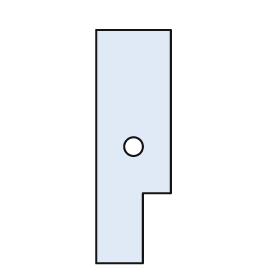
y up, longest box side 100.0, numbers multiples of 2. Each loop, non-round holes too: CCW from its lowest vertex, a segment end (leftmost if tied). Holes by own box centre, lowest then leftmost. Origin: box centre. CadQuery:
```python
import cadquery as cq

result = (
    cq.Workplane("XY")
    .moveTo(-16.0, -50.0)
    .lineTo(4.0, -50.0)
    .lineTo(4.0, -20.0)
    .lineTo(16.0, -20.0)
    .lineTo(16.0, 50.0)
    .lineTo(-16.0, 50.0)
    .close()
    .moveTo(0.0, 0.0)
    .circle(4.0)
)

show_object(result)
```